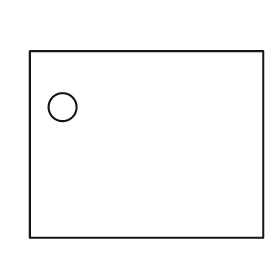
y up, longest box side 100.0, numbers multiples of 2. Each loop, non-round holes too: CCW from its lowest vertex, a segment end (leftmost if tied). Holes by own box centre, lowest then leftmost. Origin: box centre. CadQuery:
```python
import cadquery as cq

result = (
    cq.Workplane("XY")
    .moveTo(-50.0, -40.0)
    .lineTo(50.0, -40.0)
    .lineTo(50.0, 40.0)
    .lineTo(-50.0, 40.0)
    .close()
    .moveTo(-36.0, 16.0)
    .circle(6.0)
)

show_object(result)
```